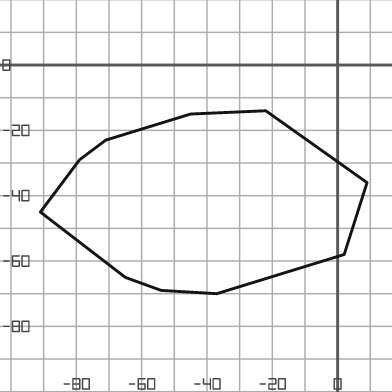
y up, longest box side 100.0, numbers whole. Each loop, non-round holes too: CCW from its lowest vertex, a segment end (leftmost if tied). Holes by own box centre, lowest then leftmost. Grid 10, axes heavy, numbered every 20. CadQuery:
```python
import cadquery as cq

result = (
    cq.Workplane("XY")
    .moveTo(-37.0, -70.0)
    .lineTo(2.0, -58.0)
    .lineTo(9.0, -36.0)
    .lineTo(-22.0, -14.0)
    .lineTo(-45.0, -15.0)
    .lineTo(-71.0, -23.0)
    .lineTo(-79.0, -29.0)
    .lineTo(-91.0, -45.0)
    .lineTo(-65.0, -65.0)
    .lineTo(-54.0, -69.0)
    .close()
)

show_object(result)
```